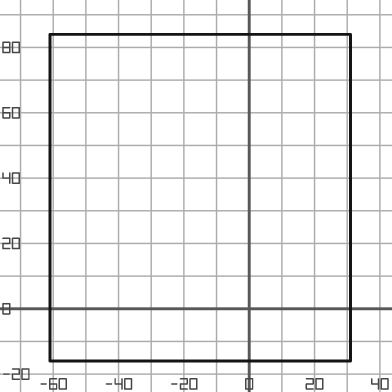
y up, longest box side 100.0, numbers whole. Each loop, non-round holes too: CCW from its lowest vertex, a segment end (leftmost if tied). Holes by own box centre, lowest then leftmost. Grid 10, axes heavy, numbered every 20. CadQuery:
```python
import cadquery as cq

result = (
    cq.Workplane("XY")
    .moveTo(-61.0, -16.0)
    .lineTo(31.0, -16.0)
    .lineTo(31.0, 84.0)
    .lineTo(-61.0, 84.0)
    .close()
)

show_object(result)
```